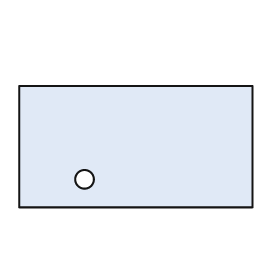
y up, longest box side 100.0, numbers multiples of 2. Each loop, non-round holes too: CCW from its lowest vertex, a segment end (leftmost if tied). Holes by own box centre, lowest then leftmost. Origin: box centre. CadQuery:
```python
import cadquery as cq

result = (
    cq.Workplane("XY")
    .moveTo(-50.0, -26.0)
    .lineTo(50.0, -26.0)
    .lineTo(50.0, 26.0)
    .lineTo(-50.0, 26.0)
    .close()
    .moveTo(-22.0, -14.0)
    .circle(4.0)
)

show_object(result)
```